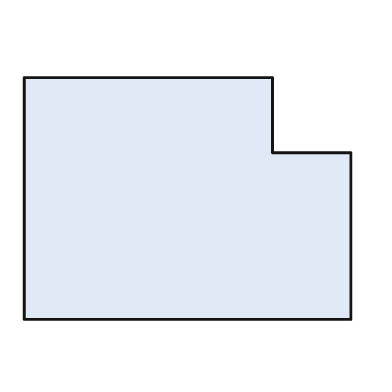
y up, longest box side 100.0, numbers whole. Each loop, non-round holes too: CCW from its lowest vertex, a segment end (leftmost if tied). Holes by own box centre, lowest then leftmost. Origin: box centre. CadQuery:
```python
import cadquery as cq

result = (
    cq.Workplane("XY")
    .moveTo(-50.0, -37.0)
    .lineTo(50.0, -37.0)
    .lineTo(50.0, 14.0)
    .lineTo(26.0, 14.0)
    .lineTo(26.0, 37.0)
    .lineTo(-50.0, 37.0)
    .close()
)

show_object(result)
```